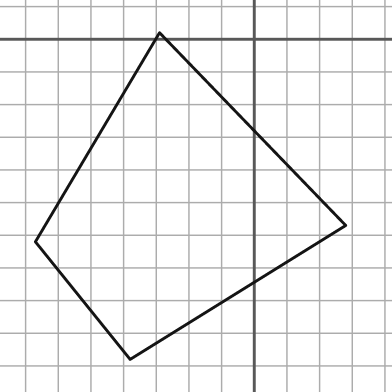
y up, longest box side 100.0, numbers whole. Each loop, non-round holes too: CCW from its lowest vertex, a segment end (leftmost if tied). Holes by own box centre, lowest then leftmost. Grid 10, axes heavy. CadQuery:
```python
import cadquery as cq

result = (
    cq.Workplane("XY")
    .moveTo(-38.0, -98.0)
    .lineTo(28.0, -57.0)
    .lineTo(-29.0, 2.0)
    .lineTo(-67.0, -62.0)
    .close()
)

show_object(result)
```